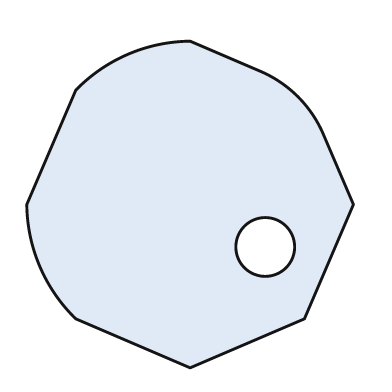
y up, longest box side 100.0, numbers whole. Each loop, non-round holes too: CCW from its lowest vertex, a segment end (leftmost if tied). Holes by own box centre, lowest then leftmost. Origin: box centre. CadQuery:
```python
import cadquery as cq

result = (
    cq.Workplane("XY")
    .moveTo(0.0, -50.0)
    .lineTo(35.0, -35.0)
    .lineTo(50.0, 0.0)
    .lineTo(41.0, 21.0)
    .threePointArc((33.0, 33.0), (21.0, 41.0))
    .lineTo(0.0, 50.0)
    .threePointArc((-19.0, 46.0), (-35.0, 35.0))
    .lineTo(-50.0, 0.0)
    .threePointArc((-46.0, -19.0), (-35.0, -35.0))
    .close()
    .moveTo(23.0, -13.0)
    .circle(9.0)
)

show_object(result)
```